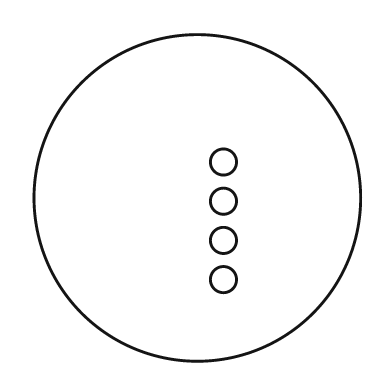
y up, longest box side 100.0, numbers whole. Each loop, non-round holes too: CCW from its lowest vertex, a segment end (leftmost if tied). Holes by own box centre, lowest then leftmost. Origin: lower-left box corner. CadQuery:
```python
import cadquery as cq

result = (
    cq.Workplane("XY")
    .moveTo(50.0, 50.0)
    .circle(50.0)
    .moveTo(58.0, 25.0)
    .circle(4.0)
    .moveTo(58.0, 37.0)
    .circle(4.0)
    .moveTo(58.0, 49.0)
    .circle(4.0)
    .moveTo(58.0, 61.0)
    .circle(4.0)
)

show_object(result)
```